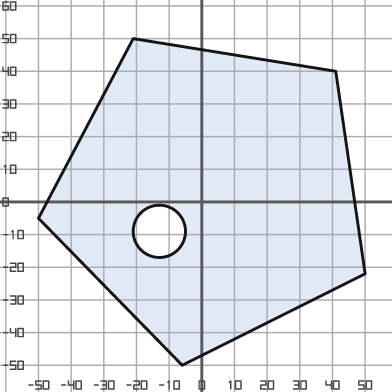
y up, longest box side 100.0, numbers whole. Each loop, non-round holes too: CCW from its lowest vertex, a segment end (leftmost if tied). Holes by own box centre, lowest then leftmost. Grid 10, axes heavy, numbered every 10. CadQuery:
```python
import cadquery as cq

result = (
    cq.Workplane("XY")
    .moveTo(-6.0, -50.0)
    .lineTo(50.0, -22.0)
    .lineTo(41.0, 40.0)
    .lineTo(-21.0, 50.0)
    .lineTo(-50.0, -5.0)
    .close()
    .moveTo(-13.0, -9.0)
    .circle(8.0)
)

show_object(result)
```